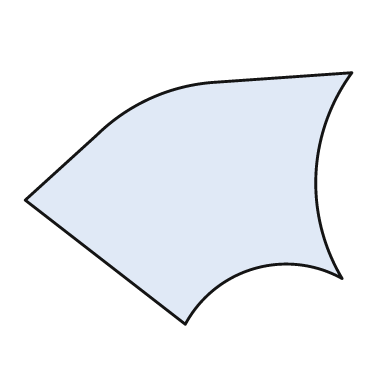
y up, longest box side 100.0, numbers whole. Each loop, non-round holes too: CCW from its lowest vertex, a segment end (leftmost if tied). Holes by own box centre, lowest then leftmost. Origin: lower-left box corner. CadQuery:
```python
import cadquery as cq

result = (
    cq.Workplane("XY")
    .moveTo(49.0, 0.0)
    .threePointArc((70.0, 17.0), (97.0, 14.0))
    .threePointArc((89.0, 46.0), (100.0, 77.0))
    .lineTo(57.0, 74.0)
    .threePointArc((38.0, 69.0), (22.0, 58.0))
    .lineTo(0.0, 38.0)
    .close()
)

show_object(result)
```